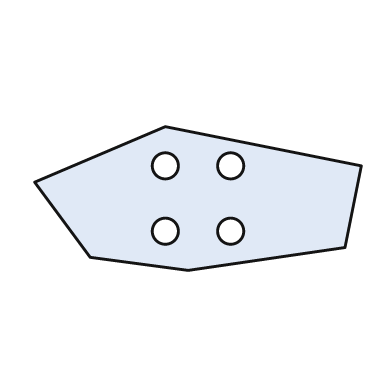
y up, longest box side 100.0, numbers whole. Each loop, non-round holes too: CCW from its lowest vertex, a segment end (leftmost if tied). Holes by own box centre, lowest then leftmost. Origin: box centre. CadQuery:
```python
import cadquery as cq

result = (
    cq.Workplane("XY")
    .moveTo(-3.0, -22.0)
    .lineTo(45.0, -15.0)
    .lineTo(50.0, 10.0)
    .lineTo(-10.0, 22.0)
    .lineTo(-50.0, 5.0)
    .lineTo(-33.0, -18.0)
    .close()
    .moveTo(-10.0, -10.0)
    .circle(4.0)
    .moveTo(10.0, -10.0)
    .circle(4.0)
    .moveTo(-10.0, 10.0)
    .circle(4.0)
    .moveTo(10.0, 10.0)
    .circle(4.0)
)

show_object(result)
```